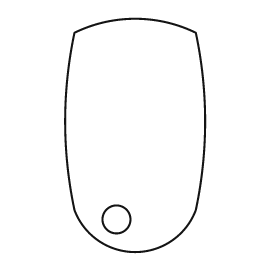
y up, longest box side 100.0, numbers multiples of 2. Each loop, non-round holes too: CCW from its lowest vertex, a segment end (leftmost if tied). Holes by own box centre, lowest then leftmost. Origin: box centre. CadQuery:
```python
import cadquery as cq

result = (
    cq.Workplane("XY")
    .moveTo(-26.0, -32.0)
    .threePointArc((0.0, -50.0), (26.0, -32.0))
    .threePointArc((30.0, 6.0), (26.0, 44.0))
    .threePointArc((0.0, 50.0), (-26.0, 44.0))
    .threePointArc((-30.0, 6.0), (-26.0, -32.0))
    .close()
    .moveTo(-8.0, -36.0)
    .circle(6.0)
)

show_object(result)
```